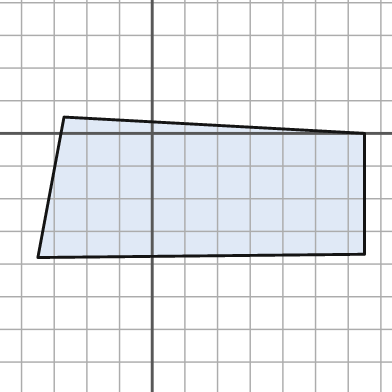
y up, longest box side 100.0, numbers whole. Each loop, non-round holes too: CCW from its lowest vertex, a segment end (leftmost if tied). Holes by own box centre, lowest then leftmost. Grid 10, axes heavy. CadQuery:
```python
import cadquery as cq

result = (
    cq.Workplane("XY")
    .moveTo(-35.0, -38.0)
    .lineTo(65.0, -37.0)
    .lineTo(65.0, 0.0)
    .lineTo(-27.0, 5.0)
    .close()
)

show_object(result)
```